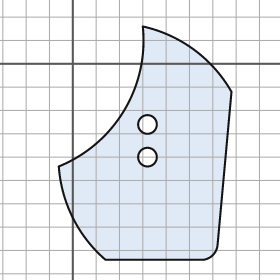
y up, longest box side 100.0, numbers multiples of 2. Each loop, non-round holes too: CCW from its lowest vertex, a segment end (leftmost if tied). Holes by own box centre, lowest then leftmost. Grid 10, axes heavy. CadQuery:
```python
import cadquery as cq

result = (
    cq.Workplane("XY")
    .moveTo(14.0, -84.0)
    .lineTo(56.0, -84.0)
    .threePointArc((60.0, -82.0), (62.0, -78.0))
    .lineTo(68.0, -12.0)
    .threePointArc((52.0, 6.0), (30.0, 16.0))
    .threePointArc((22.0, -20.0), (-6.0, -44.0))
    .threePointArc((0.0, -66.0), (14.0, -84.0))
    .close()
    .moveTo(32.0, -40.0)
    .circle(4.0)
    .moveTo(32.0, -26.0)
    .circle(4.0)
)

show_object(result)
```